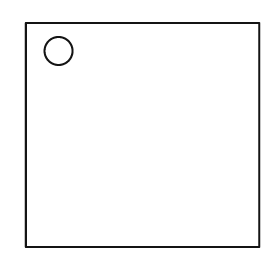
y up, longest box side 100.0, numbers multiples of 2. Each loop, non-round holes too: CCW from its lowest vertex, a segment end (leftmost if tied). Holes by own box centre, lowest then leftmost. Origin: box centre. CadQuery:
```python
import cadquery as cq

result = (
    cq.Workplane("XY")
    .moveTo(-50.0, -48.0)
    .lineTo(50.0, -48.0)
    .lineTo(50.0, 48.0)
    .lineTo(-50.0, 48.0)
    .close()
    .moveTo(-36.0, 36.0)
    .circle(6.0)
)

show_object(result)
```